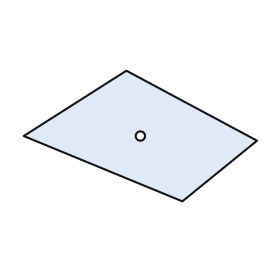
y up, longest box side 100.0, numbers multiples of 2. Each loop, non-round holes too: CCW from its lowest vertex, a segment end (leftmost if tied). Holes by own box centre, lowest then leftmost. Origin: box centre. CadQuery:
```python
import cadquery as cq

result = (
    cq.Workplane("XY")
    .moveTo(18.0, -28.0)
    .lineTo(50.0, -2.0)
    .lineTo(-6.0, 28.0)
    .lineTo(-50.0, 0.0)
    .close()
    .moveTo(0.0, 0.0)
    .circle(2.0)
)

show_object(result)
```